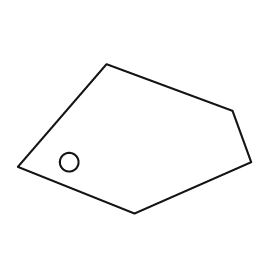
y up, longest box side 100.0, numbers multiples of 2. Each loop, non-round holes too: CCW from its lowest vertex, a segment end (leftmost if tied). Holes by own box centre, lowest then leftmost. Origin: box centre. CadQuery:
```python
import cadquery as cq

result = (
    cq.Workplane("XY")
    .moveTo(0.0, -32.0)
    .lineTo(50.0, -10.0)
    .lineTo(42.0, 12.0)
    .lineTo(-12.0, 32.0)
    .lineTo(-50.0, -12.0)
    .close()
    .moveTo(-28.0, -10.0)
    .circle(4.0)
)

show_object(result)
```